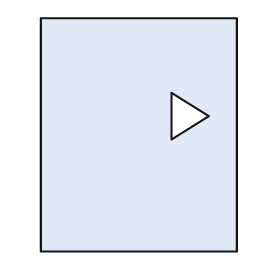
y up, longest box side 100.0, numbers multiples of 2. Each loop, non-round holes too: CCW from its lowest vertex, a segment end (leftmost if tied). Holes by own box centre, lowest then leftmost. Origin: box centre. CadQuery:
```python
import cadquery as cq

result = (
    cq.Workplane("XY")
    .moveTo(-42.0, -50.0)
    .lineTo(42.0, -50.0)
    .lineTo(42.0, 50.0)
    .lineTo(-42.0, 50.0)
    .close()
    .moveTo(14.0, -2.0)
    .lineTo(30.0, 8.0)
    .lineTo(14.0, 18.0)
    .close()
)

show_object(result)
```